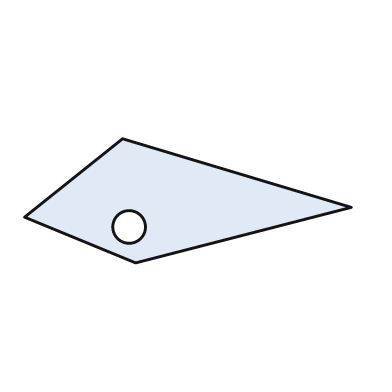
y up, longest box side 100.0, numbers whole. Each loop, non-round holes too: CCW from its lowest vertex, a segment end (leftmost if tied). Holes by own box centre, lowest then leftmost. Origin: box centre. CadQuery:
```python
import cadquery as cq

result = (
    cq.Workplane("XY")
    .moveTo(-16.0, -19.0)
    .lineTo(50.0, -2.0)
    .lineTo(-20.0, 19.0)
    .lineTo(-50.0, -5.0)
    .close()
    .moveTo(-18.0, -8.0)
    .circle(5.0)
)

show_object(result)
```